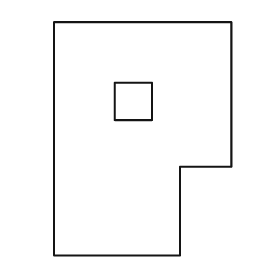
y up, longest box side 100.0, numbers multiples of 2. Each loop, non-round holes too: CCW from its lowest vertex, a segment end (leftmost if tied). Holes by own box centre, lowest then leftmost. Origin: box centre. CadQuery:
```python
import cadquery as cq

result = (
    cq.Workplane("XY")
    .moveTo(-38.0, -50.0)
    .lineTo(16.0, -50.0)
    .lineTo(16.0, -12.0)
    .lineTo(38.0, -12.0)
    .lineTo(38.0, 50.0)
    .lineTo(-38.0, 50.0)
    .close()
    .moveTo(-12.0, 8.0)
    .lineTo(4.0, 8.0)
    .lineTo(4.0, 24.0)
    .lineTo(-12.0, 24.0)
    .close()
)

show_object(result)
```